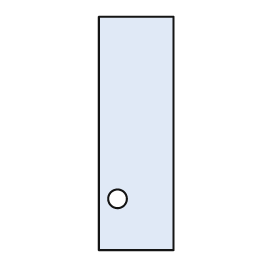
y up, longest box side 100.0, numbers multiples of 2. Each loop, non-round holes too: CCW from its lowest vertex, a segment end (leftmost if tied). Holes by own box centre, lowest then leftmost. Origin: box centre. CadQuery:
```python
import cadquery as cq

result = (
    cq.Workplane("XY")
    .moveTo(-16.0, -50.0)
    .lineTo(16.0, -50.0)
    .lineTo(16.0, 50.0)
    .lineTo(-16.0, 50.0)
    .close()
    .moveTo(-8.0, -28.0)
    .circle(4.0)
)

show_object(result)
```